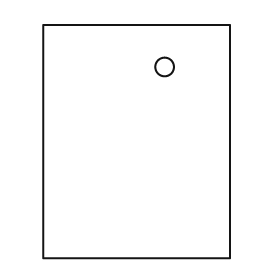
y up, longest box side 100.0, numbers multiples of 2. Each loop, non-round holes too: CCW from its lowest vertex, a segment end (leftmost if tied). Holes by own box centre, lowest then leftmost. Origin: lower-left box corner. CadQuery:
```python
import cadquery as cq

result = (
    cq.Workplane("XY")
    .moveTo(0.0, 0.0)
    .lineTo(80.0, 0.0)
    .lineTo(80.0, 100.0)
    .lineTo(0.0, 100.0)
    .close()
    .moveTo(52.0, 82.0)
    .circle(4.0)
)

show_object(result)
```